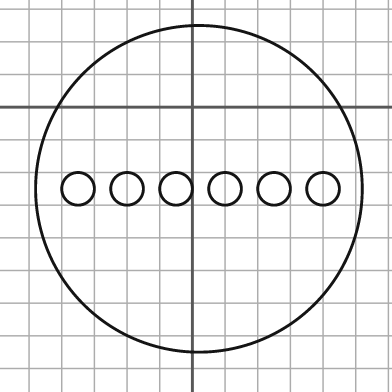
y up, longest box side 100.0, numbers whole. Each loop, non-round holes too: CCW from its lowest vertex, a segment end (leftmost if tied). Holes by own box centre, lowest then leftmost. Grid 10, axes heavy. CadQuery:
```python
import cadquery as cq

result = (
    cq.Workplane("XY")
    .moveTo(2.0, -25.0)
    .circle(50.0)
    .moveTo(-35.0, -25.0)
    .circle(5.0)
    .moveTo(-20.0, -25.0)
    .circle(5.0)
    .moveTo(-5.0, -25.0)
    .circle(5.0)
    .moveTo(10.0, -25.0)
    .circle(5.0)
    .moveTo(25.0, -25.0)
    .circle(5.0)
    .moveTo(40.0, -25.0)
    .circle(5.0)
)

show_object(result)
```